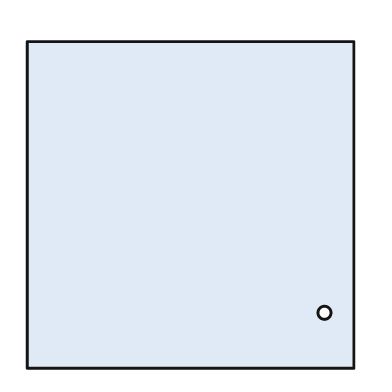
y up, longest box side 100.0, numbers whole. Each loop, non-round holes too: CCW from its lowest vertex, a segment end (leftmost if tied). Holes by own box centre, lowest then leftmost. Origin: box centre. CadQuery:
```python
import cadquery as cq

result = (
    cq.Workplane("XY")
    .moveTo(-50.0, -50.0)
    .lineTo(50.0, -50.0)
    .lineTo(50.0, 50.0)
    .lineTo(-50.0, 50.0)
    .close()
    .moveTo(41.0, -33.0)
    .circle(2.0)
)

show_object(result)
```